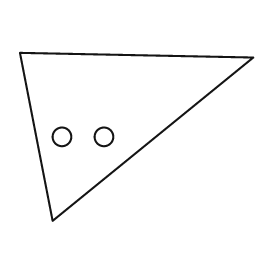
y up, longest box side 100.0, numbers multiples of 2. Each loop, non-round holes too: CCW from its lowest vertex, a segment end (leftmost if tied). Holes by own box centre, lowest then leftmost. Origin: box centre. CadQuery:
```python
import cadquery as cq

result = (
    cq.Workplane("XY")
    .moveTo(-36.0, -36.0)
    .lineTo(50.0, 34.0)
    .lineTo(-50.0, 36.0)
    .close()
    .moveTo(-32.0, 0.0)
    .circle(4.0)
    .moveTo(-14.0, 0.0)
    .circle(4.0)
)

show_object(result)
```